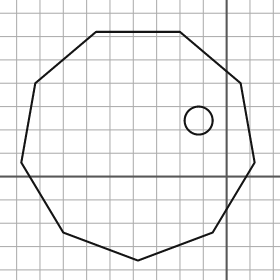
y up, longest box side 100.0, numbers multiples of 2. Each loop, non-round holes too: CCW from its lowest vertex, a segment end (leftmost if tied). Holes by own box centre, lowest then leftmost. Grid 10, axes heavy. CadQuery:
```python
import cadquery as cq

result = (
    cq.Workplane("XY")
    .moveTo(-38.0, -36.0)
    .lineTo(-6.0, -24.0)
    .lineTo(12.0, 6.0)
    .lineTo(6.0, 40.0)
    .lineTo(-20.0, 62.0)
    .lineTo(-56.0, 62.0)
    .lineTo(-82.0, 40.0)
    .lineTo(-88.0, 6.0)
    .lineTo(-70.0, -24.0)
    .close()
    .moveTo(-12.0, 24.0)
    .circle(6.0)
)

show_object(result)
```